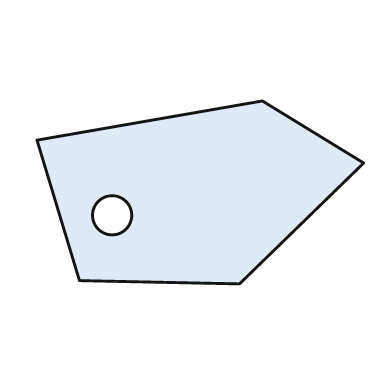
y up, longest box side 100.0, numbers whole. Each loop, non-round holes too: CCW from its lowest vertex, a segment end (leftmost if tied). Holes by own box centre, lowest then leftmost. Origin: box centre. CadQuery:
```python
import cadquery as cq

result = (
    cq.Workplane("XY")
    .moveTo(12.0, -28.0)
    .lineTo(50.0, 9.0)
    .lineTo(19.0, 28.0)
    .lineTo(-50.0, 16.0)
    .lineTo(-37.0, -27.0)
    .close()
    .moveTo(-27.0, -7.0)
    .circle(6.0)
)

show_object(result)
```